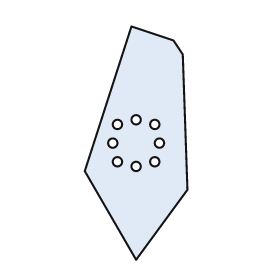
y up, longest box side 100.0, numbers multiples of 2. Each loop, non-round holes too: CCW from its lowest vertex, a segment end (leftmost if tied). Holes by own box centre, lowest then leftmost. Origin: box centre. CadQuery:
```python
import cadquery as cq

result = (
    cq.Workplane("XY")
    .moveTo(0.0, -50.0)
    .lineTo(22.0, -20.0)
    .lineTo(20.0, 38.0)
    .lineTo(16.0, 44.0)
    .lineTo(-2.0, 50.0)
    .lineTo(-22.0, -12.0)
    .close()
    .moveTo(0.0, -10.0)
    .circle(2.0)
    .moveTo(-8.0, -8.0)
    .circle(2.0)
    .moveTo(8.0, -8.0)
    .circle(2.0)
    .moveTo(-10.0, 0.0)
    .circle(2.0)
    .moveTo(10.0, 0.0)
    .circle(2.0)
    .moveTo(-8.0, 8.0)
    .circle(2.0)
    .moveTo(8.0, 8.0)
    .circle(2.0)
    .moveTo(0.0, 10.0)
    .circle(2.0)
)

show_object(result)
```